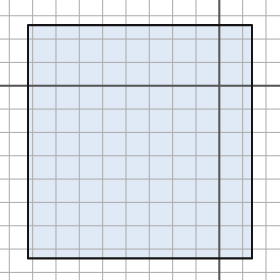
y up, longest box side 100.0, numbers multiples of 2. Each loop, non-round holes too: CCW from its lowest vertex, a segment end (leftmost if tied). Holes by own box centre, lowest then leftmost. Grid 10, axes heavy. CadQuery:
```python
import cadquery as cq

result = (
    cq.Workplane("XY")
    .moveTo(-82.0, -74.0)
    .lineTo(14.0, -74.0)
    .lineTo(14.0, 26.0)
    .lineTo(-82.0, 26.0)
    .close()
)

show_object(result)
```